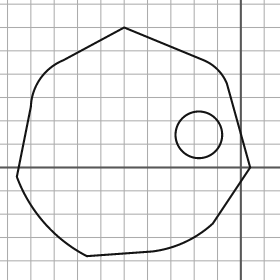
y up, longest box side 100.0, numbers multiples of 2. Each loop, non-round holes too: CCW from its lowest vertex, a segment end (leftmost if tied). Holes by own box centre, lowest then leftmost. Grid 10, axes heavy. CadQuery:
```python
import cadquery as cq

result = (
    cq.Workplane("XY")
    .moveTo(-66.0, -38.0)
    .lineTo(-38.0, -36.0)
    .threePointArc((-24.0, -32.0), (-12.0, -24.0))
    .lineTo(4.0, 0.0)
    .lineTo(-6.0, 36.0)
    .threePointArc((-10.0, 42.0), (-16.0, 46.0))
    .lineTo(-50.0, 60.0)
    .lineTo(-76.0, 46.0)
    .threePointArc((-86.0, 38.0), (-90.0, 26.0))
    .lineTo(-96.0, -4.0)
    .threePointArc((-84.0, -24.0), (-66.0, -38.0))
    .close()
    .moveTo(-18.0, 14.0)
    .circle(10.0)
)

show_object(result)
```